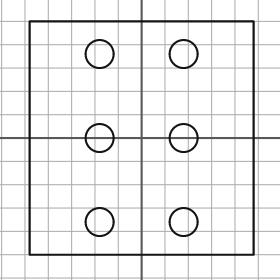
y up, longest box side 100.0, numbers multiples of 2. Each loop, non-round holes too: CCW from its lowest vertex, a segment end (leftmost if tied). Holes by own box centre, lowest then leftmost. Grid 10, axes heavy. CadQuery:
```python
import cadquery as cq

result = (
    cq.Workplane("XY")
    .moveTo(-48.0, -50.0)
    .lineTo(48.0, -50.0)
    .lineTo(48.0, 50.0)
    .lineTo(-48.0, 50.0)
    .close()
    .moveTo(-18.0, -36.0)
    .circle(6.0)
    .moveTo(18.0, -36.0)
    .circle(6.0)
    .moveTo(-18.0, 0.0)
    .circle(6.0)
    .moveTo(18.0, 0.0)
    .circle(6.0)
    .moveTo(-18.0, 36.0)
    .circle(6.0)
    .moveTo(18.0, 36.0)
    .circle(6.0)
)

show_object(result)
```